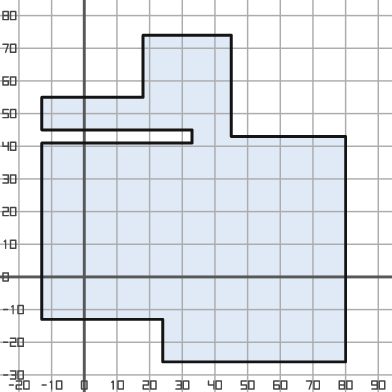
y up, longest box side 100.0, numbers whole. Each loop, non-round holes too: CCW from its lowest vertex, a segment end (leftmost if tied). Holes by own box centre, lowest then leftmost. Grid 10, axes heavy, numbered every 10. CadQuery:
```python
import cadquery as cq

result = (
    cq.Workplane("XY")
    .moveTo(24.0, -26.0)
    .lineTo(80.0, -26.0)
    .lineTo(80.0, 43.0)
    .lineTo(45.0, 43.0)
    .lineTo(45.0, 74.0)
    .lineTo(18.0, 74.0)
    .lineTo(18.0, 55.0)
    .lineTo(-13.0, 55.0)
    .lineTo(-13.0, 45.0)
    .lineTo(33.0, 45.0)
    .lineTo(33.0, 41.0)
    .lineTo(-13.0, 41.0)
    .lineTo(-13.0, -13.0)
    .lineTo(24.0, -13.0)
    .close()
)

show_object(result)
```